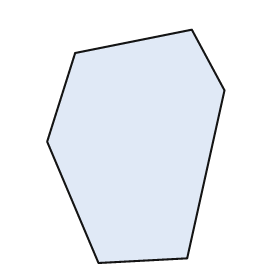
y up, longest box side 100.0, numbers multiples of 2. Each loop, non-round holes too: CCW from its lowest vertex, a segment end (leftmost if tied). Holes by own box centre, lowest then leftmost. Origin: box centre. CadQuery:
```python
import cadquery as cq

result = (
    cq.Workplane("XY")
    .moveTo(-16.0, -50.0)
    .lineTo(22.0, -48.0)
    .lineTo(38.0, 24.0)
    .lineTo(24.0, 50.0)
    .lineTo(-26.0, 40.0)
    .lineTo(-38.0, 2.0)
    .close()
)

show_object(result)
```